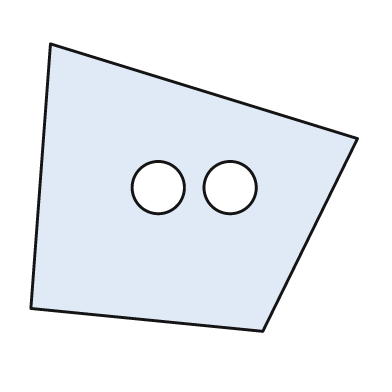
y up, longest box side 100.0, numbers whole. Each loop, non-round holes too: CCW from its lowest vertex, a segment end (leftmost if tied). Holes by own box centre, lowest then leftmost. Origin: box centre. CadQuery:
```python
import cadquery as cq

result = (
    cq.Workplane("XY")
    .moveTo(21.0, -44.0)
    .lineTo(50.0, 15.0)
    .lineTo(-44.0, 44.0)
    .lineTo(-50.0, -37.0)
    .close()
    .moveTo(-11.0, 0.0)
    .circle(8.0)
    .moveTo(11.0, 0.0)
    .circle(8.0)
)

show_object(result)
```